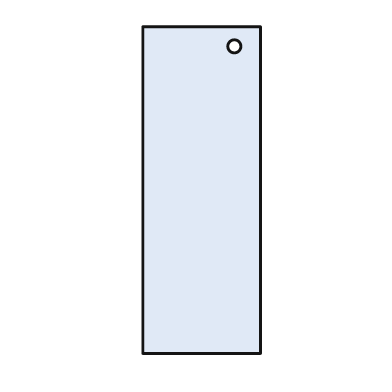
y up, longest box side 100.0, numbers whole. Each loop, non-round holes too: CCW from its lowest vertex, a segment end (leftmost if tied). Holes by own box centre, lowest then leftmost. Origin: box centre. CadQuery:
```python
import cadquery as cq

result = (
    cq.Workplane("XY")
    .moveTo(-18.0, -50.0)
    .lineTo(18.0, -50.0)
    .lineTo(18.0, 50.0)
    .lineTo(-18.0, 50.0)
    .close()
    .moveTo(10.0, 44.0)
    .circle(2.0)
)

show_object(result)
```